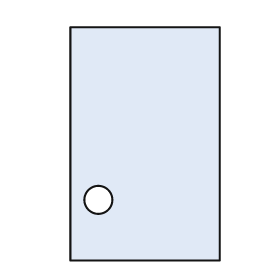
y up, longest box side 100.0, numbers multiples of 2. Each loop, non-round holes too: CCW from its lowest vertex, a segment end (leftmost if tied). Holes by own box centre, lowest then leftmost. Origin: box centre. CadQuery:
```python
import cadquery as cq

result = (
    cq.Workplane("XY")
    .moveTo(-32.0, -50.0)
    .lineTo(32.0, -50.0)
    .lineTo(32.0, 50.0)
    .lineTo(-32.0, 50.0)
    .close()
    .moveTo(-20.0, -24.0)
    .circle(6.0)
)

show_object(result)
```